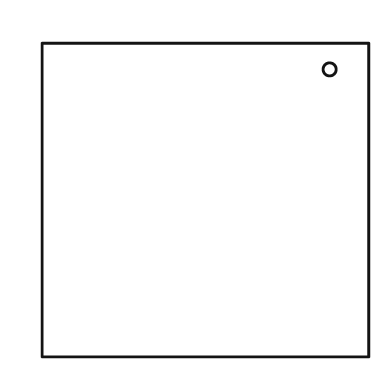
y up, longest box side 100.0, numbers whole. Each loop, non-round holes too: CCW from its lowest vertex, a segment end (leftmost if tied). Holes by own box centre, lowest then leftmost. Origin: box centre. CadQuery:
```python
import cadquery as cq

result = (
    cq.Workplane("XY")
    .moveTo(-50.0, -48.0)
    .lineTo(50.0, -48.0)
    .lineTo(50.0, 48.0)
    .lineTo(-50.0, 48.0)
    .close()
    .moveTo(38.0, 40.0)
    .circle(2.0)
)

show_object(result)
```